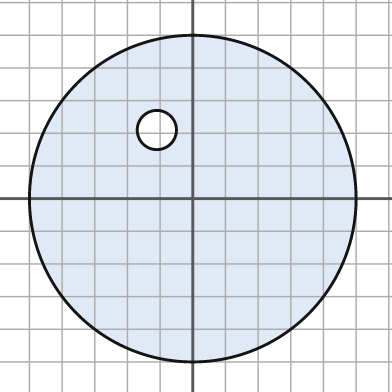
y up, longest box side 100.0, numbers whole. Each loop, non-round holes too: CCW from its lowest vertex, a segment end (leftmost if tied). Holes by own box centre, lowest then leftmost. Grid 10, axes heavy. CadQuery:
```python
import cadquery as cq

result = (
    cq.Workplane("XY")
    .moveTo(0.0, 0.0)
    .circle(50.0)
    .moveTo(-11.0, 21.0)
    .circle(6.0)
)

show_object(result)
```